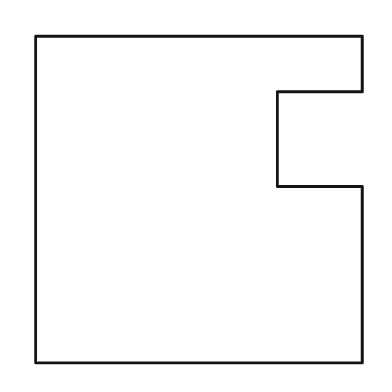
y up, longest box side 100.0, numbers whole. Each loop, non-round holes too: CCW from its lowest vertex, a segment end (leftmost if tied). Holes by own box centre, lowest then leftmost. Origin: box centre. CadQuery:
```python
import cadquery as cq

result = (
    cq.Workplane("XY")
    .moveTo(-50.0, -50.0)
    .lineTo(50.0, -50.0)
    .lineTo(50.0, 4.0)
    .lineTo(24.0, 4.0)
    .lineTo(24.0, 33.0)
    .lineTo(50.0, 33.0)
    .lineTo(50.0, 50.0)
    .lineTo(-50.0, 50.0)
    .close()
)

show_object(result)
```